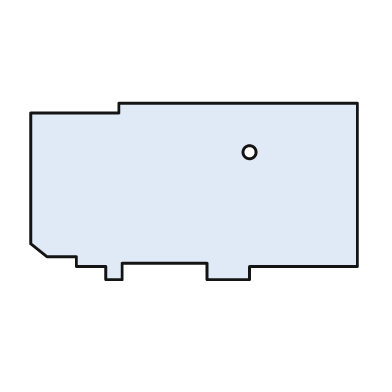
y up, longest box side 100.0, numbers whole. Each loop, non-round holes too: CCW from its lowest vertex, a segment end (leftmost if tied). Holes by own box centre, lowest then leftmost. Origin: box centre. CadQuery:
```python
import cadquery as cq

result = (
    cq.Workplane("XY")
    .moveTo(-27.0, -27.0)
    .lineTo(-22.0, -27.0)
    .lineTo(-22.0, -22.0)
    .lineTo(4.0, -22.0)
    .lineTo(4.0, -27.0)
    .lineTo(17.0, -27.0)
    .lineTo(17.0, -23.0)
    .lineTo(50.0, -23.0)
    .lineTo(50.0, 27.0)
    .lineTo(-23.0, 27.0)
    .lineTo(-23.0, 24.0)
    .lineTo(-50.0, 24.0)
    .lineTo(-50.0, -16.0)
    .lineTo(-45.0, -20.0)
    .lineTo(-36.0, -20.0)
    .lineTo(-36.0, -23.0)
    .lineTo(-27.0, -23.0)
    .close()
    .moveTo(17.0, 12.0)
    .circle(2.0)
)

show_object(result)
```